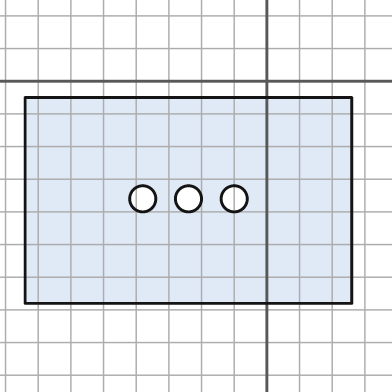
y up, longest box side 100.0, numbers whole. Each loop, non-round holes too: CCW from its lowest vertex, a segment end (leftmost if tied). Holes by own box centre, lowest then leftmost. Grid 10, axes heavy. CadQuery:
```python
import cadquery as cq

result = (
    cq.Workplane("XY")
    .moveTo(-74.0, -68.0)
    .lineTo(26.0, -68.0)
    .lineTo(26.0, -5.0)
    .lineTo(-74.0, -5.0)
    .close()
    .moveTo(-38.0, -36.0)
    .circle(4.0)
    .moveTo(-24.0, -36.0)
    .circle(4.0)
    .moveTo(-10.0, -36.0)
    .circle(4.0)
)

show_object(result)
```